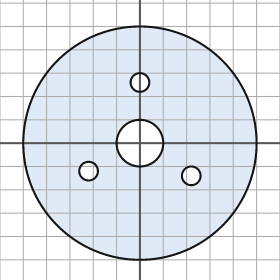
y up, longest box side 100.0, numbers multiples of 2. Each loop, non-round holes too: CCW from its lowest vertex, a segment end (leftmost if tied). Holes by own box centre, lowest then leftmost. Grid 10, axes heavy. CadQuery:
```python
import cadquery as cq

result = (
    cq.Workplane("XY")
    .moveTo(0.0, 0.0)
    .circle(50.0)
    .moveTo(22.0, -14.0)
    .circle(4.0)
    .moveTo(-22.0, -12.0)
    .circle(4.0)
    .moveTo(0.0, 0.0)
    .circle(10.0)
    .moveTo(0.0, 26.0)
    .circle(4.0)
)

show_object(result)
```